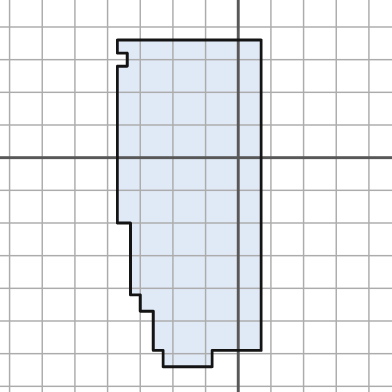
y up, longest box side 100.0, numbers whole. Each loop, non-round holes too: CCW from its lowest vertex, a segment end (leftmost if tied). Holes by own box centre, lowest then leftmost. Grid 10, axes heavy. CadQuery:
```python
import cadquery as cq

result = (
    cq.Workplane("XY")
    .moveTo(-23.0, -64.0)
    .lineTo(-8.0, -64.0)
    .lineTo(-8.0, -59.0)
    .lineTo(7.0, -59.0)
    .lineTo(7.0, 36.0)
    .lineTo(-37.0, 36.0)
    .lineTo(-37.0, 32.0)
    .lineTo(-34.0, 32.0)
    .lineTo(-34.0, 28.0)
    .lineTo(-37.0, 28.0)
    .lineTo(-37.0, -20.0)
    .lineTo(-33.0, -20.0)
    .lineTo(-33.0, -42.0)
    .lineTo(-30.0, -42.0)
    .lineTo(-30.0, -47.0)
    .lineTo(-26.0, -47.0)
    .lineTo(-26.0, -59.0)
    .lineTo(-23.0, -59.0)
    .close()
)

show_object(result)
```